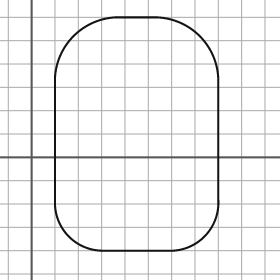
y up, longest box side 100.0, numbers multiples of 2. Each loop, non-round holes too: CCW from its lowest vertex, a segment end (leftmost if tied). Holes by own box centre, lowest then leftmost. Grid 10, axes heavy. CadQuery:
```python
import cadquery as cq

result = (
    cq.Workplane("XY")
    .moveTo(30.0, -40.0)
    .lineTo(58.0, -40.0)
    .threePointArc((74.0, -34.0), (80.0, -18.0))
    .lineTo(80.0, 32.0)
    .threePointArc((72.0, 52.0), (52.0, 60.0))
    .lineTo(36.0, 60.0)
    .threePointArc((18.0, 52.0), (10.0, 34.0))
    .lineTo(10.0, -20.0)
    .threePointArc((16.0, -34.0), (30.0, -40.0))
    .close()
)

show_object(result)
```